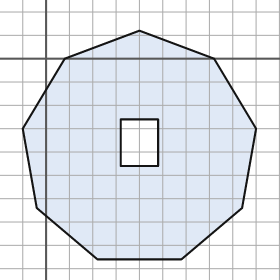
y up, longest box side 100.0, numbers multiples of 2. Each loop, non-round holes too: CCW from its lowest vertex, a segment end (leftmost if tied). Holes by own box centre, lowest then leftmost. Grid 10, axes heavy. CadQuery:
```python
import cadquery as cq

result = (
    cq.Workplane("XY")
    .moveTo(22.0, -86.0)
    .lineTo(58.0, -86.0)
    .lineTo(84.0, -64.0)
    .lineTo(90.0, -30.0)
    .lineTo(72.0, 0.0)
    .lineTo(40.0, 12.0)
    .lineTo(8.0, 0.0)
    .lineTo(-10.0, -30.0)
    .lineTo(-4.0, -64.0)
    .close()
    .moveTo(32.0, -46.0)
    .lineTo(48.0, -46.0)
    .lineTo(48.0, -26.0)
    .lineTo(32.0, -26.0)
    .close()
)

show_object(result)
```